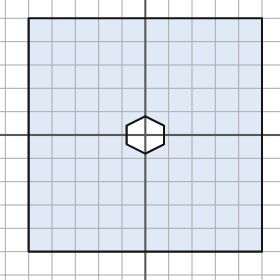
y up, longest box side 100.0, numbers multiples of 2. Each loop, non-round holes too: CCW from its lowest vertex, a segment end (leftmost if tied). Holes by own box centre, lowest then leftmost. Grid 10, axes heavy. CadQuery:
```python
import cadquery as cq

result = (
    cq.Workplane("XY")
    .moveTo(-50.0, -50.0)
    .lineTo(50.0, -50.0)
    .lineTo(50.0, 50.0)
    .lineTo(-50.0, 50.0)
    .close()
    .moveTo(0.0, -8.0)
    .lineTo(8.0, -4.0)
    .lineTo(8.0, 4.0)
    .lineTo(0.0, 8.0)
    .lineTo(-8.0, 4.0)
    .lineTo(-8.0, -4.0)
    .close()
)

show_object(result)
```